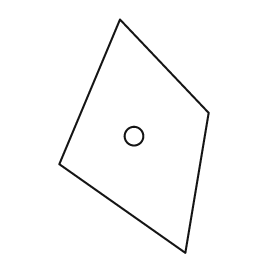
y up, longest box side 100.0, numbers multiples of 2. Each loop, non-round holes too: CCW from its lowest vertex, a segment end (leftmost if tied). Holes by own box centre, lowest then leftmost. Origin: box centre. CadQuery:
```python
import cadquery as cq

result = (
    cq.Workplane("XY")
    .moveTo(22.0, -50.0)
    .lineTo(32.0, 10.0)
    .lineTo(-6.0, 50.0)
    .lineTo(-32.0, -12.0)
    .close()
    .moveTo(0.0, 0.0)
    .circle(4.0)
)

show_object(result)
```